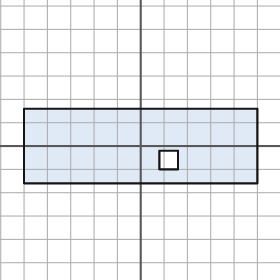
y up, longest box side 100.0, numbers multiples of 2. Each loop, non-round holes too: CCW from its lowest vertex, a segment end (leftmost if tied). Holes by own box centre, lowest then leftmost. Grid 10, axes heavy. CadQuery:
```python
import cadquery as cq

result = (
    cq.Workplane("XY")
    .moveTo(-50.0, -16.0)
    .lineTo(50.0, -16.0)
    .lineTo(50.0, 16.0)
    .lineTo(-50.0, 16.0)
    .close()
    .moveTo(8.0, -10.0)
    .lineTo(16.0, -10.0)
    .lineTo(16.0, -2.0)
    .lineTo(8.0, -2.0)
    .close()
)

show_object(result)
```